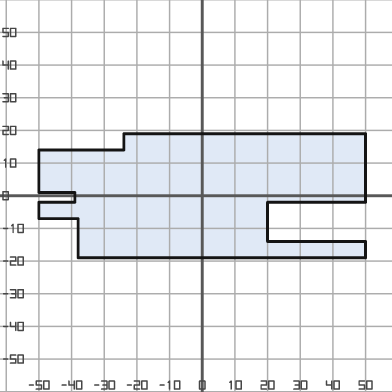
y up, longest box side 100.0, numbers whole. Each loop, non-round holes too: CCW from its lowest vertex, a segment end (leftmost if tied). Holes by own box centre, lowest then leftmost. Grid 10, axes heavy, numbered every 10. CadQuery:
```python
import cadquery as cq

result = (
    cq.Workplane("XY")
    .moveTo(-38.0, -19.0)
    .lineTo(50.0, -19.0)
    .lineTo(50.0, -14.0)
    .lineTo(20.0, -14.0)
    .lineTo(20.0, -2.0)
    .lineTo(50.0, -2.0)
    .lineTo(50.0, 19.0)
    .lineTo(-24.0, 19.0)
    .lineTo(-24.0, 14.0)
    .lineTo(-50.0, 14.0)
    .lineTo(-50.0, 1.0)
    .lineTo(-39.0, 1.0)
    .lineTo(-39.0, -2.0)
    .lineTo(-50.0, -2.0)
    .lineTo(-50.0, -7.0)
    .lineTo(-38.0, -7.0)
    .close()
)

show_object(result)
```